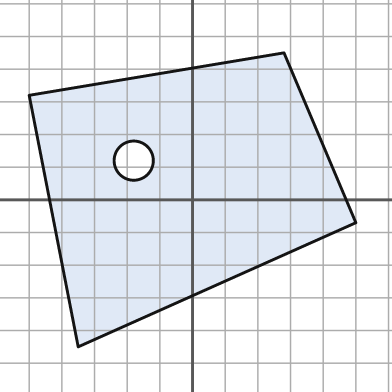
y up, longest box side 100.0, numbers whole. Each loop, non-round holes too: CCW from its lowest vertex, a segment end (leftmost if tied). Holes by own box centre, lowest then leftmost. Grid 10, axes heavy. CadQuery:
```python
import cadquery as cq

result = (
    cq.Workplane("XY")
    .moveTo(-35.0, -45.0)
    .lineTo(50.0, -7.0)
    .lineTo(28.0, 45.0)
    .lineTo(-50.0, 32.0)
    .close()
    .moveTo(-18.0, 12.0)
    .circle(6.0)
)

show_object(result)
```